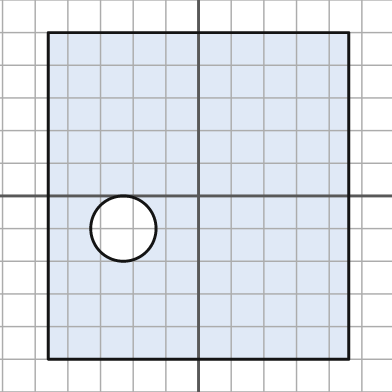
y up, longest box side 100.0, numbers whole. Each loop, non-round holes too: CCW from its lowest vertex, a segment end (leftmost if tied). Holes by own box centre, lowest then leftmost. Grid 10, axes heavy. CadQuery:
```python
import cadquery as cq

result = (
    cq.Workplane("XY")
    .moveTo(-46.0, -50.0)
    .lineTo(46.0, -50.0)
    .lineTo(46.0, 50.0)
    .lineTo(-46.0, 50.0)
    .close()
    .moveTo(-23.0, -10.0)
    .circle(10.0)
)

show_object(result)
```